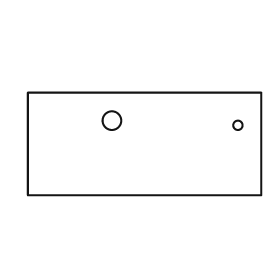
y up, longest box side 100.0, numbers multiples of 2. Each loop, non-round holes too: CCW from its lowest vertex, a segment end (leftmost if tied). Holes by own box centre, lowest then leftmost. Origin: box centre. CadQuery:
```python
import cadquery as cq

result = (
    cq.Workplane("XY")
    .moveTo(-50.0, -22.0)
    .lineTo(50.0, -22.0)
    .lineTo(50.0, 22.0)
    .lineTo(-50.0, 22.0)
    .close()
    .moveTo(40.0, 8.0)
    .circle(2.0)
    .moveTo(-14.0, 10.0)
    .circle(4.0)
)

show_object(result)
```